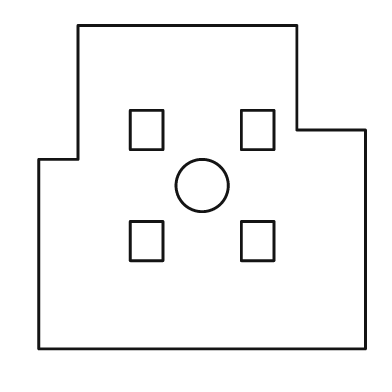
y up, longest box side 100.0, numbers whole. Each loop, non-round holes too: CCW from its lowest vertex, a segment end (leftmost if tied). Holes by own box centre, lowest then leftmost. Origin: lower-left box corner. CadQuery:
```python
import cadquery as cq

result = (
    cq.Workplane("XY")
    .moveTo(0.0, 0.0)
    .lineTo(100.0, 0.0)
    .lineTo(100.0, 67.0)
    .lineTo(79.0, 67.0)
    .lineTo(79.0, 99.0)
    .lineTo(12.0, 99.0)
    .lineTo(12.0, 58.0)
    .lineTo(0.0, 58.0)
    .close()
    .moveTo(28.0, 27.0)
    .lineTo(38.0, 27.0)
    .lineTo(38.0, 39.0)
    .lineTo(28.0, 39.0)
    .close()
    .moveTo(62.0, 27.0)
    .lineTo(72.0, 27.0)
    .lineTo(72.0, 39.0)
    .lineTo(62.0, 39.0)
    .close()
    .moveTo(50.0, 50.0)
    .circle(8.0)
    .moveTo(28.0, 61.0)
    .lineTo(38.0, 61.0)
    .lineTo(38.0, 73.0)
    .lineTo(28.0, 73.0)
    .close()
    .moveTo(62.0, 61.0)
    .lineTo(72.0, 61.0)
    .lineTo(72.0, 73.0)
    .lineTo(62.0, 73.0)
    .close()
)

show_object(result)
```